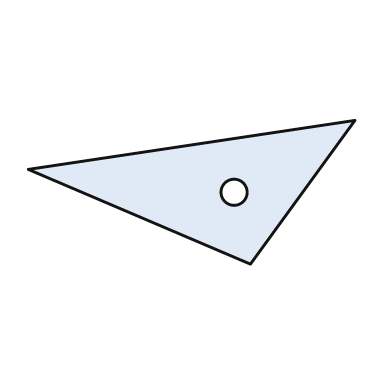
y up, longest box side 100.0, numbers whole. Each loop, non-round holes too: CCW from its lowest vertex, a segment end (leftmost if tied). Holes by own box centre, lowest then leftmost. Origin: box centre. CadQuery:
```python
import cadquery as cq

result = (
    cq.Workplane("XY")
    .moveTo(18.0, -22.0)
    .lineTo(50.0, 22.0)
    .lineTo(-50.0, 7.0)
    .close()
    .moveTo(13.0, 0.0)
    .circle(4.0)
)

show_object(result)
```